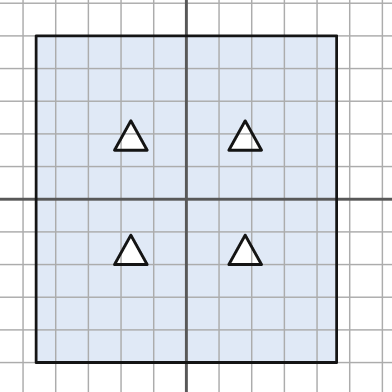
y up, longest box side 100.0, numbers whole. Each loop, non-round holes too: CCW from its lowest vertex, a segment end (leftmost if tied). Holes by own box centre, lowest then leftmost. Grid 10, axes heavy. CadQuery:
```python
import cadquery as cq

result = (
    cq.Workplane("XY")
    .moveTo(-46.0, -50.0)
    .lineTo(46.0, -50.0)
    .lineTo(46.0, 50.0)
    .lineTo(-46.0, 50.0)
    .close()
    .moveTo(-22.0, -20.0)
    .lineTo(-12.0, -20.0)
    .lineTo(-17.0, -11.0)
    .close()
    .moveTo(13.0, -20.0)
    .lineTo(23.0, -20.0)
    .lineTo(18.0, -11.0)
    .close()
    .moveTo(-22.0, 15.0)
    .lineTo(-12.0, 15.0)
    .lineTo(-17.0, 24.0)
    .close()
    .moveTo(13.0, 15.0)
    .lineTo(23.0, 15.0)
    .lineTo(18.0, 24.0)
    .close()
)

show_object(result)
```